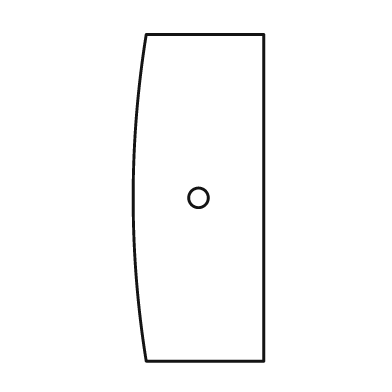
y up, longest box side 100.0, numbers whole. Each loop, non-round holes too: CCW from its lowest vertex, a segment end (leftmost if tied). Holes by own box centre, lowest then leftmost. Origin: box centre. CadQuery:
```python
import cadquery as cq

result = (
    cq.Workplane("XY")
    .moveTo(-16.0, -50.0)
    .lineTo(20.0, -50.0)
    .lineTo(20.0, 50.0)
    .lineTo(-16.0, 50.0)
    .threePointArc((-20.0, 0.0), (-16.0, -50.0))
    .close()
    .moveTo(0.0, 0.0)
    .circle(3.0)
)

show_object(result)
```